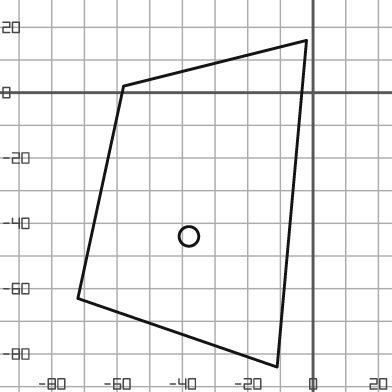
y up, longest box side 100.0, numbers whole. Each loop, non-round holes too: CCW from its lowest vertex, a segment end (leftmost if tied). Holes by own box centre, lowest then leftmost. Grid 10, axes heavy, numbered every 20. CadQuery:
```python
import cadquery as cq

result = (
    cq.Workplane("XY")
    .moveTo(-11.0, -84.0)
    .lineTo(-2.0, 16.0)
    .lineTo(-58.0, 2.0)
    .lineTo(-72.0, -63.0)
    .close()
    .moveTo(-38.0, -44.0)
    .circle(3.0)
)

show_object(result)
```